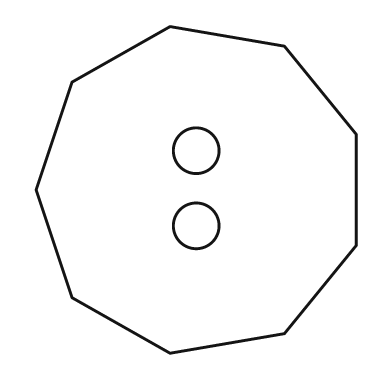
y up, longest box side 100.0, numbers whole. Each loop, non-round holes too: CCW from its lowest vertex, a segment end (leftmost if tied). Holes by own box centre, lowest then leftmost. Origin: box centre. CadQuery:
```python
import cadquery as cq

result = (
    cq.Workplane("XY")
    .moveTo(-8.0, -50.0)
    .lineTo(27.0, -44.0)
    .lineTo(49.0, -17.0)
    .lineTo(49.0, 17.0)
    .lineTo(27.0, 44.0)
    .lineTo(-8.0, 50.0)
    .lineTo(-38.0, 33.0)
    .lineTo(-49.0, 0.0)
    .lineTo(-38.0, -33.0)
    .close()
    .moveTo(0.0, -11.0)
    .circle(7.0)
    .moveTo(0.0, 12.0)
    .circle(7.0)
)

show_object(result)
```